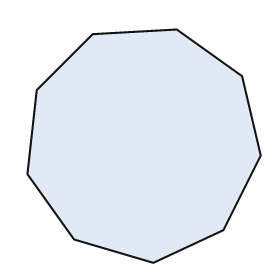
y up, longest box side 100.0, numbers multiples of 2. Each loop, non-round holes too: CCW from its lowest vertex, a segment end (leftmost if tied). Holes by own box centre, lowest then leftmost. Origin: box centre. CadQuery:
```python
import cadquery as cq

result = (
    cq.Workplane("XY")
    .moveTo(4.0, -50.0)
    .lineTo(34.0, -36.0)
    .lineTo(50.0, -4.0)
    .lineTo(42.0, 30.0)
    .lineTo(14.0, 50.0)
    .lineTo(-22.0, 48.0)
    .lineTo(-46.0, 24.0)
    .lineTo(-50.0, -12.0)
    .lineTo(-30.0, -40.0)
    .close()
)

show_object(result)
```